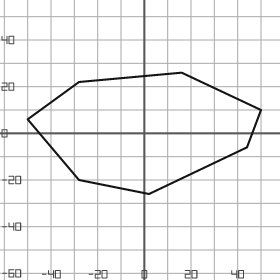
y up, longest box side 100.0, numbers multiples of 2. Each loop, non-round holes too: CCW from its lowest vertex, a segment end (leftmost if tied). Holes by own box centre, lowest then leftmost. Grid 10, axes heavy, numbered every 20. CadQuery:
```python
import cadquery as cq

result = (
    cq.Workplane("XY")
    .moveTo(2.0, -26.0)
    .lineTo(44.0, -6.0)
    .lineTo(50.0, 10.0)
    .lineTo(16.0, 26.0)
    .lineTo(-28.0, 22.0)
    .lineTo(-50.0, 6.0)
    .lineTo(-28.0, -20.0)
    .close()
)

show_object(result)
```